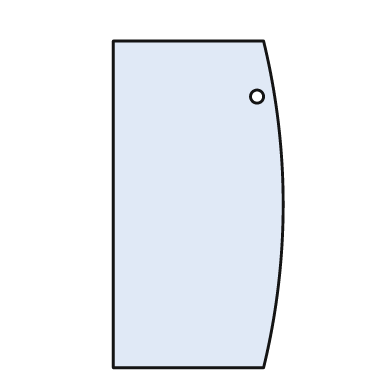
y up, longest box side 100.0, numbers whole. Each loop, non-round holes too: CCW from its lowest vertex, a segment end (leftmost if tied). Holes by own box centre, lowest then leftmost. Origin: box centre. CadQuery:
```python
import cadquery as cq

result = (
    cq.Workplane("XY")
    .moveTo(-26.0, -50.0)
    .lineTo(20.0, -50.0)
    .threePointArc((26.0, 0.0), (20.0, 50.0))
    .lineTo(-26.0, 50.0)
    .close()
    .moveTo(18.0, 33.0)
    .circle(2.0)
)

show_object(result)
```